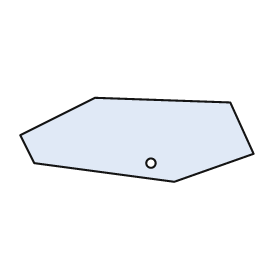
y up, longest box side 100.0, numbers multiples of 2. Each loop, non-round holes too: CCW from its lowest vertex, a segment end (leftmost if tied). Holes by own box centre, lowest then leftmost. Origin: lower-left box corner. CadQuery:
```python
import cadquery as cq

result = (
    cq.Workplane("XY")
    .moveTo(66.0, 0.0)
    .lineTo(100.0, 12.0)
    .lineTo(90.0, 34.0)
    .lineTo(32.0, 36.0)
    .lineTo(0.0, 20.0)
    .lineTo(6.0, 8.0)
    .close()
    .moveTo(56.0, 8.0)
    .circle(2.0)
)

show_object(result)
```